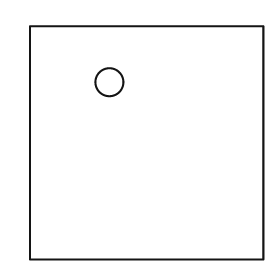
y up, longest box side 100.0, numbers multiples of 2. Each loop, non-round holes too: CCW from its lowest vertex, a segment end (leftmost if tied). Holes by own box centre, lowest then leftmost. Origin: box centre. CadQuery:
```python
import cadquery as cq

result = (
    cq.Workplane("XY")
    .moveTo(-50.0, -50.0)
    .lineTo(50.0, -50.0)
    .lineTo(50.0, 50.0)
    .lineTo(-50.0, 50.0)
    .close()
    .moveTo(-16.0, 26.0)
    .circle(6.0)
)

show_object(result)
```